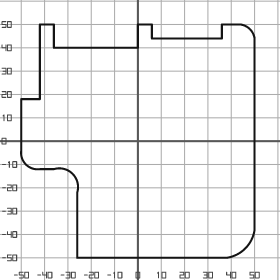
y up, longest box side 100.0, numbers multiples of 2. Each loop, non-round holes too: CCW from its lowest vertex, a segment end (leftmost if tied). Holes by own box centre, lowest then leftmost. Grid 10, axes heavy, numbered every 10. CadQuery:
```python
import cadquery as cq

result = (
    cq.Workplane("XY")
    .moveTo(-26.0, -50.0)
    .lineTo(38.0, -50.0)
    .threePointArc((46.0, -46.0), (50.0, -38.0))
    .lineTo(50.0, 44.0)
    .threePointArc((48.0, 48.0), (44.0, 50.0))
    .lineTo(36.0, 50.0)
    .lineTo(36.0, 44.0)
    .lineTo(6.0, 44.0)
    .lineTo(6.0, 50.0)
    .lineTo(0.0, 50.0)
    .lineTo(0.0, 40.0)
    .lineTo(-36.0, 40.0)
    .lineTo(-36.0, 50.0)
    .lineTo(-42.0, 50.0)
    .lineTo(-42.0, 18.0)
    .lineTo(-50.0, 18.0)
    .lineTo(-50.0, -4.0)
    .threePointArc((-48.0, -10.0), (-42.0, -12.0))
    .lineTo(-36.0, -12.0)
    .threePointArc((-28.0, -14.0), (-26.0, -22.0))
    .close()
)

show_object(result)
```